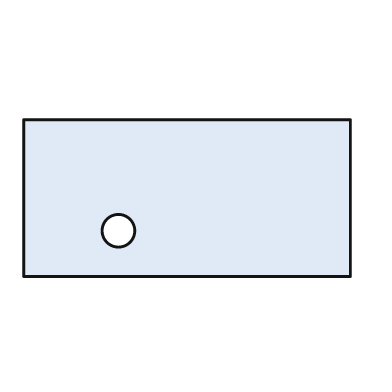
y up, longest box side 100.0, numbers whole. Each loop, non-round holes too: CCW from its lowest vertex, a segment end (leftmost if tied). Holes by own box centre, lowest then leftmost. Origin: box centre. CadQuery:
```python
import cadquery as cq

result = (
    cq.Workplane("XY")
    .moveTo(-50.0, -24.0)
    .lineTo(50.0, -24.0)
    .lineTo(50.0, 24.0)
    .lineTo(-50.0, 24.0)
    .close()
    .moveTo(-21.0, -10.0)
    .circle(5.0)
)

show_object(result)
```